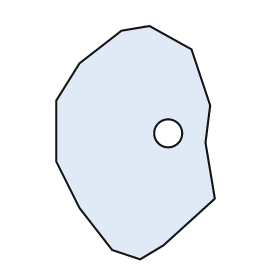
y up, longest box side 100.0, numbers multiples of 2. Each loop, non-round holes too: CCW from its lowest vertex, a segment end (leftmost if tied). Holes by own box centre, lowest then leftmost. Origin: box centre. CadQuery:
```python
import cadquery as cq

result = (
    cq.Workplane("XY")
    .moveTo(2.0, -50.0)
    .lineTo(12.0, -44.0)
    .lineTo(34.0, -24.0)
    .lineTo(30.0, 0.0)
    .lineTo(32.0, 16.0)
    .lineTo(24.0, 40.0)
    .lineTo(6.0, 50.0)
    .lineTo(-6.0, 48.0)
    .lineTo(-24.0, 34.0)
    .lineTo(-34.0, 18.0)
    .lineTo(-34.0, -8.0)
    .lineTo(-24.0, -28.0)
    .lineTo(-10.0, -46.0)
    .close()
    .moveTo(14.0, 4.0)
    .circle(6.0)
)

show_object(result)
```